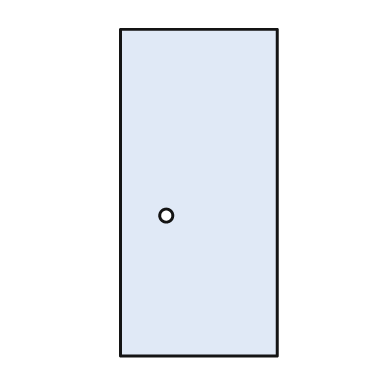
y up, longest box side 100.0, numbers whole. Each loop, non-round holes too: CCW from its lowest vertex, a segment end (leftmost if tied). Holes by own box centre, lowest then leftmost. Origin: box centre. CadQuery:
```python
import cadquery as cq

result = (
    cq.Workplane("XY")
    .moveTo(-24.0, -50.0)
    .lineTo(24.0, -50.0)
    .lineTo(24.0, 50.0)
    .lineTo(-24.0, 50.0)
    .close()
    .moveTo(-10.0, -7.0)
    .circle(2.0)
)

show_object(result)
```